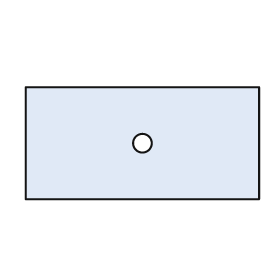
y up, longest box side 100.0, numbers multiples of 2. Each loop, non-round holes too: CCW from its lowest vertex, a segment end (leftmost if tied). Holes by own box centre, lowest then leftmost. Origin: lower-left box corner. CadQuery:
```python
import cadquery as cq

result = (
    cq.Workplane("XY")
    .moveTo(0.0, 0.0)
    .lineTo(100.0, 0.0)
    .lineTo(100.0, 48.0)
    .lineTo(0.0, 48.0)
    .close()
    .moveTo(50.0, 24.0)
    .circle(4.0)
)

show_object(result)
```